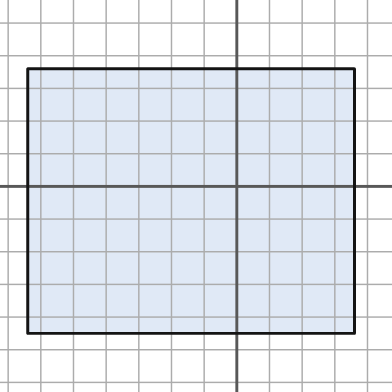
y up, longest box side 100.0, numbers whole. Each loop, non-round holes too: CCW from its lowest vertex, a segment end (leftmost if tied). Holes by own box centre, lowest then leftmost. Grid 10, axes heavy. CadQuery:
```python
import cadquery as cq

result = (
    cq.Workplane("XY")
    .moveTo(-64.0, -45.0)
    .lineTo(36.0, -45.0)
    .lineTo(36.0, 36.0)
    .lineTo(-64.0, 36.0)
    .close()
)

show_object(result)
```